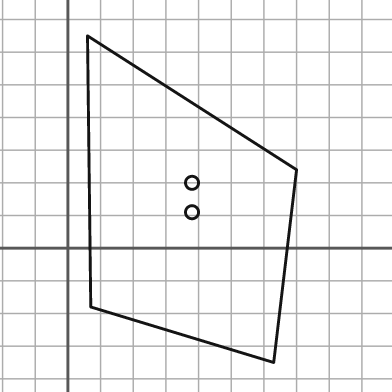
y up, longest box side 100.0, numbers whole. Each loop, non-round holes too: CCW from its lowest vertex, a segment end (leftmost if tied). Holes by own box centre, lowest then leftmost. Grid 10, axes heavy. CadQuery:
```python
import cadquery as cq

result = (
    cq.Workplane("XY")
    .moveTo(63.0, -35.0)
    .lineTo(70.0, 24.0)
    .lineTo(6.0, 65.0)
    .lineTo(7.0, -18.0)
    .close()
    .moveTo(38.0, 11.0)
    .circle(2.0)
    .moveTo(38.0, 20.0)
    .circle(2.0)
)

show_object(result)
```